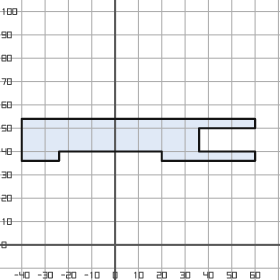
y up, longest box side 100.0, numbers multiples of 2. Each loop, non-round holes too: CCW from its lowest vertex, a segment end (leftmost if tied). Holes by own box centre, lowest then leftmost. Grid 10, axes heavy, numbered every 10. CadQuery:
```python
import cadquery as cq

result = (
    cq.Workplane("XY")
    .moveTo(-40.0, 36.0)
    .lineTo(-24.0, 36.0)
    .lineTo(-24.0, 40.0)
    .lineTo(20.0, 40.0)
    .lineTo(20.0, 36.0)
    .lineTo(60.0, 36.0)
    .lineTo(60.0, 40.0)
    .lineTo(36.0, 40.0)
    .lineTo(36.0, 50.0)
    .lineTo(60.0, 50.0)
    .lineTo(60.0, 54.0)
    .lineTo(-40.0, 54.0)
    .close()
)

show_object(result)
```